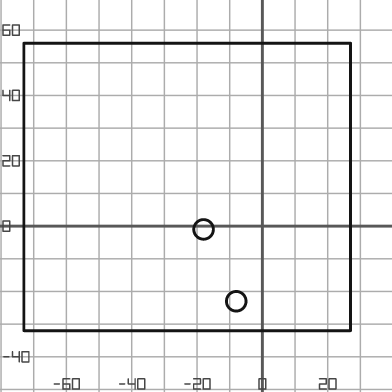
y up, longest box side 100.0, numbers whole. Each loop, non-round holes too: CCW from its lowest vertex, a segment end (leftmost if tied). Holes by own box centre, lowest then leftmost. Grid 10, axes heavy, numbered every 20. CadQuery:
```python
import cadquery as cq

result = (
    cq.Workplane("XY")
    .moveTo(-73.0, -32.0)
    .lineTo(27.0, -32.0)
    .lineTo(27.0, 56.0)
    .lineTo(-73.0, 56.0)
    .close()
    .moveTo(-8.0, -23.0)
    .circle(3.0)
    .moveTo(-18.0, -1.0)
    .circle(3.0)
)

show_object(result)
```